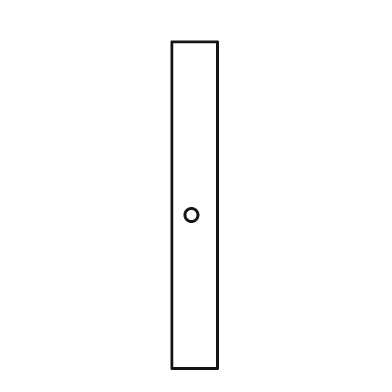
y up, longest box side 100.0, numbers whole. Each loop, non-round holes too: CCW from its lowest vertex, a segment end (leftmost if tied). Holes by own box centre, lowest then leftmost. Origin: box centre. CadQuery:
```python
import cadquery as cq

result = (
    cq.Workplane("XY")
    .moveTo(-7.0, -50.0)
    .lineTo(7.0, -50.0)
    .lineTo(7.0, 50.0)
    .lineTo(-7.0, 50.0)
    .close()
    .moveTo(-1.0, -3.0)
    .circle(2.0)
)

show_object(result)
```